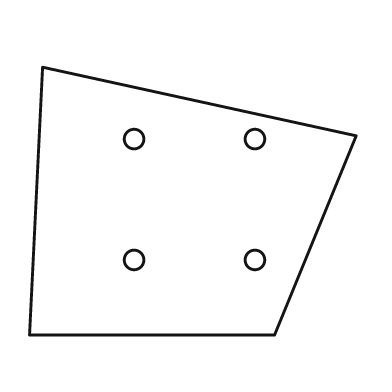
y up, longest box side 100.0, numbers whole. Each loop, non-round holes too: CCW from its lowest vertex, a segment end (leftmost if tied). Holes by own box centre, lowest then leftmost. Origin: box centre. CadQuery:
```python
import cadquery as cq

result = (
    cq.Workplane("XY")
    .moveTo(-50.0, -41.0)
    .lineTo(25.0, -41.0)
    .lineTo(50.0, 20.0)
    .lineTo(-46.0, 41.0)
    .close()
    .moveTo(-18.0, -18.0)
    .circle(3.0)
    .moveTo(19.0, -18.0)
    .circle(3.0)
    .moveTo(-18.0, 19.0)
    .circle(3.0)
    .moveTo(19.0, 19.0)
    .circle(3.0)
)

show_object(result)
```